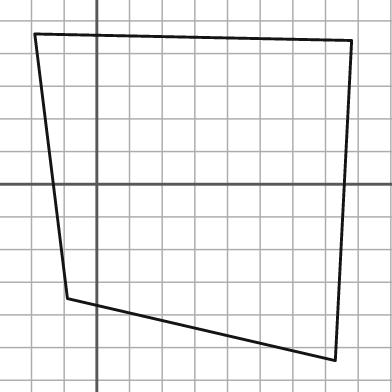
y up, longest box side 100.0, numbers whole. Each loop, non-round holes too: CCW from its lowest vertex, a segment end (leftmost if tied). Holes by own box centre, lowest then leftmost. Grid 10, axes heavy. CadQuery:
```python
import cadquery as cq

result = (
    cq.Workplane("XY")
    .moveTo(73.0, -54.0)
    .lineTo(78.0, 44.0)
    .lineTo(-19.0, 46.0)
    .lineTo(-9.0, -35.0)
    .close()
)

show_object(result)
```